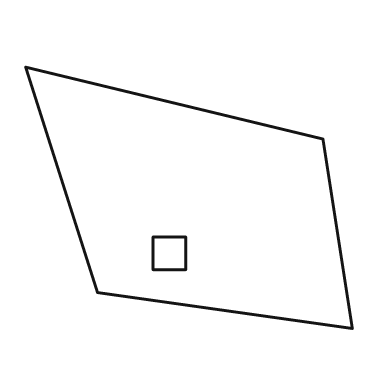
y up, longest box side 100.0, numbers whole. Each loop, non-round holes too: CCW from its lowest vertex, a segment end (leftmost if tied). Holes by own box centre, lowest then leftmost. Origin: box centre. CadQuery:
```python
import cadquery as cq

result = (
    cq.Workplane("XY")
    .moveTo(50.0, -40.0)
    .lineTo(41.0, 18.0)
    .lineTo(-50.0, 40.0)
    .lineTo(-28.0, -29.0)
    .close()
    .moveTo(-11.0, -22.0)
    .lineTo(-1.0, -22.0)
    .lineTo(-1.0, -12.0)
    .lineTo(-11.0, -12.0)
    .close()
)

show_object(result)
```